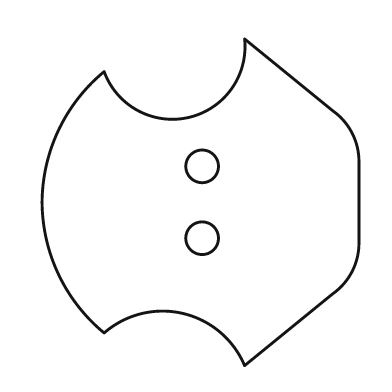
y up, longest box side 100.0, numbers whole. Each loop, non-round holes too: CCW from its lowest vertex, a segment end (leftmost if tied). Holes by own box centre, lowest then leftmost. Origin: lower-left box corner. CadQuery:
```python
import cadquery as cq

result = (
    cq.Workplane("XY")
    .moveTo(62.0, 0.0)
    .lineTo(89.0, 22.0)
    .threePointArc((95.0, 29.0), (97.0, 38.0))
    .lineTo(97.0, 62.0)
    .threePointArc((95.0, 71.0), (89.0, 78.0))
    .lineTo(62.0, 100.0)
    .threePointArc((45.0, 76.0), (19.0, 90.0))
    .threePointArc((5.0, 72.0), (0.0, 50.0))
    .threePointArc((5.0, 28.0), (19.0, 10.0))
    .threePointArc((43.0, 16.0), (62.0, 0.0))
    .close()
    .moveTo(49.0, 39.0)
    .circle(5.0)
    .moveTo(49.0, 61.0)
    .circle(5.0)
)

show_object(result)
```